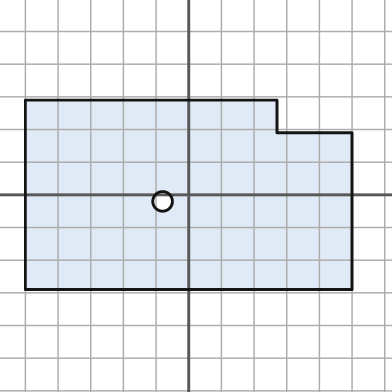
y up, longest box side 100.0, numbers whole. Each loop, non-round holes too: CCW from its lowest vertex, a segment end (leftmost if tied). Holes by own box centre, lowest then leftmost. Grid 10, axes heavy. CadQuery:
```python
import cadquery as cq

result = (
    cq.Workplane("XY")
    .moveTo(-50.0, -29.0)
    .lineTo(50.0, -29.0)
    .lineTo(50.0, 19.0)
    .lineTo(27.0, 19.0)
    .lineTo(27.0, 29.0)
    .lineTo(-50.0, 29.0)
    .close()
    .moveTo(-8.0, -2.0)
    .circle(3.0)
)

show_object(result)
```